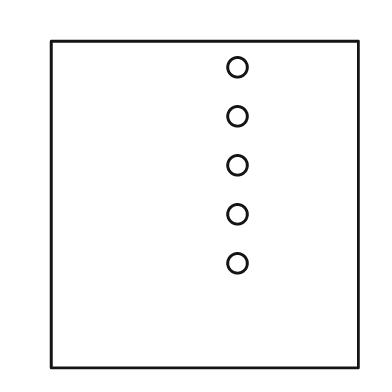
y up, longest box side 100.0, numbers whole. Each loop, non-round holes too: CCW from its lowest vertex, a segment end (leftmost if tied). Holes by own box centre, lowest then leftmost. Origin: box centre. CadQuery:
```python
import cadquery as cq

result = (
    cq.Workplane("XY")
    .moveTo(-47.0, -50.0)
    .lineTo(47.0, -50.0)
    .lineTo(47.0, 50.0)
    .lineTo(-47.0, 50.0)
    .close()
    .moveTo(10.0, -18.0)
    .circle(3.0)
    .moveTo(10.0, -3.0)
    .circle(3.0)
    .moveTo(10.0, 12.0)
    .circle(3.0)
    .moveTo(10.0, 27.0)
    .circle(3.0)
    .moveTo(10.0, 42.0)
    .circle(3.0)
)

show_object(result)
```